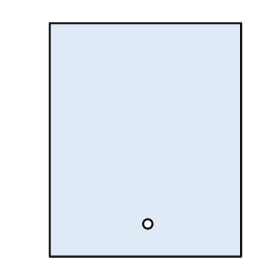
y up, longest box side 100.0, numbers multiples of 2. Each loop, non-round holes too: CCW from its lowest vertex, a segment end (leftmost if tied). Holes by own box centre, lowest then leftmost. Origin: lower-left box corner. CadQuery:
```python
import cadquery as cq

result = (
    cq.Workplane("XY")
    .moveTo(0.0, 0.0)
    .lineTo(82.0, 0.0)
    .lineTo(82.0, 100.0)
    .lineTo(0.0, 100.0)
    .close()
    .moveTo(42.0, 14.0)
    .circle(2.0)
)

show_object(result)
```